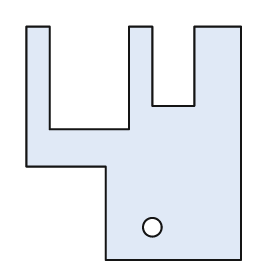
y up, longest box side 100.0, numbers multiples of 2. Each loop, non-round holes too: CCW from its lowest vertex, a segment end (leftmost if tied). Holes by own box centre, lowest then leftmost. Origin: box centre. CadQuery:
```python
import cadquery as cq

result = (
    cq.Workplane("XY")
    .moveTo(-12.0, -50.0)
    .lineTo(46.0, -50.0)
    .lineTo(46.0, 50.0)
    .lineTo(26.0, 50.0)
    .lineTo(26.0, 16.0)
    .lineTo(8.0, 16.0)
    .lineTo(8.0, 50.0)
    .lineTo(-2.0, 50.0)
    .lineTo(-2.0, 6.0)
    .lineTo(-36.0, 6.0)
    .lineTo(-36.0, 50.0)
    .lineTo(-46.0, 50.0)
    .lineTo(-46.0, -10.0)
    .lineTo(-12.0, -10.0)
    .close()
    .moveTo(8.0, -36.0)
    .circle(4.0)
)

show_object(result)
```